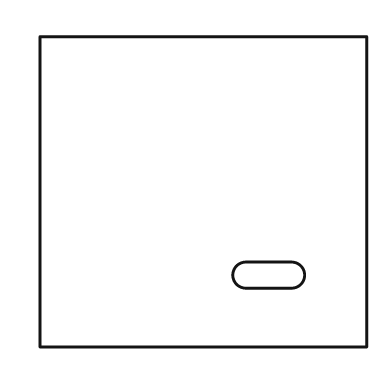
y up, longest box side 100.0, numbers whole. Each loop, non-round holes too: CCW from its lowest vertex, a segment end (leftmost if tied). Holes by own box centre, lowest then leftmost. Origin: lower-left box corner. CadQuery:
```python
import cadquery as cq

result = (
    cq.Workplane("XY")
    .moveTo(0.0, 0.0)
    .lineTo(100.0, 0.0)
    .lineTo(100.0, 95.0)
    .lineTo(0.0, 95.0)
    .close()
    .moveTo(63.0, 18.0)
    .lineTo(77.0, 18.0)
    .threePointArc((81.0, 22.0), (77.0, 26.0))
    .lineTo(63.0, 26.0)
    .threePointArc((59.0, 22.0), (63.0, 18.0))
    .close()
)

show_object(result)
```